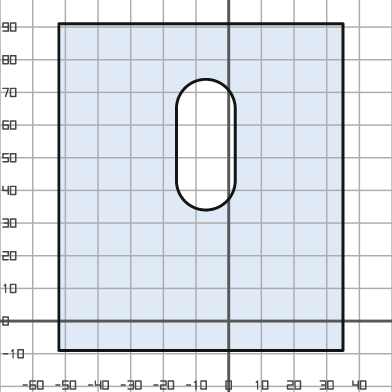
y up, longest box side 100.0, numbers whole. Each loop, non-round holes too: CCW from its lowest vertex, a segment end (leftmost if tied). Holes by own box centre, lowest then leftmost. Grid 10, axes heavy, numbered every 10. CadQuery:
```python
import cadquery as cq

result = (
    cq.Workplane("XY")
    .moveTo(-52.0, -9.0)
    .lineTo(35.0, -9.0)
    .lineTo(35.0, 91.0)
    .lineTo(-52.0, 91.0)
    .close()
    .moveTo(-16.0, 43.0)
    .threePointArc((-7.0, 34.0), (2.0, 43.0))
    .lineTo(2.0, 65.0)
    .threePointArc((-7.0, 74.0), (-16.0, 65.0))
    .close()
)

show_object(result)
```